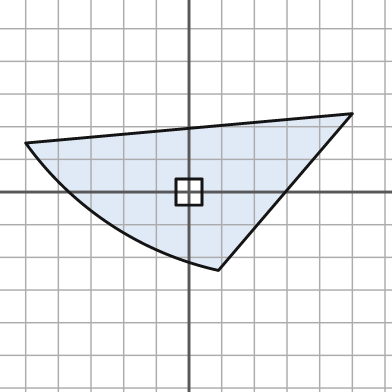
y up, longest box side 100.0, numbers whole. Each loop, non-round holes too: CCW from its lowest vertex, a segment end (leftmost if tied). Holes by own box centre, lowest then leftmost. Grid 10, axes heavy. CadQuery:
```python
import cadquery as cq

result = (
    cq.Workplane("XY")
    .moveTo(9.0, -24.0)
    .lineTo(50.0, 24.0)
    .lineTo(-50.0, 15.0)
    .threePointArc((-24.0, -10.0), (9.0, -24.0))
    .close()
    .moveTo(-4.0, -4.0)
    .lineTo(4.0, -4.0)
    .lineTo(4.0, 4.0)
    .lineTo(-4.0, 4.0)
    .close()
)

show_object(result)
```